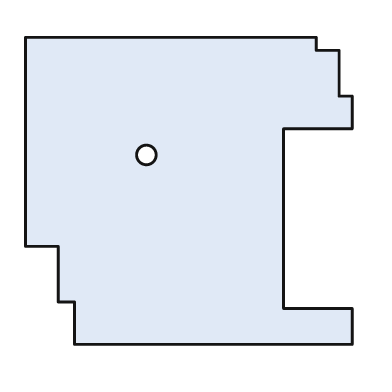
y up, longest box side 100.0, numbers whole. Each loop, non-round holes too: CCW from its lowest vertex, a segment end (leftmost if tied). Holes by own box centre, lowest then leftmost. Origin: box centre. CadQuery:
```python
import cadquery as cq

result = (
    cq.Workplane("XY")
    .moveTo(-35.0, -47.0)
    .lineTo(50.0, -47.0)
    .lineTo(50.0, -36.0)
    .lineTo(29.0, -36.0)
    .lineTo(29.0, 19.0)
    .lineTo(50.0, 19.0)
    .lineTo(50.0, 29.0)
    .lineTo(46.0, 29.0)
    .lineTo(46.0, 43.0)
    .lineTo(39.0, 43.0)
    .lineTo(39.0, 47.0)
    .lineTo(-50.0, 47.0)
    .lineTo(-50.0, -17.0)
    .lineTo(-40.0, -17.0)
    .lineTo(-40.0, -34.0)
    .lineTo(-35.0, -34.0)
    .close()
    .moveTo(-13.0, 11.0)
    .circle(3.0)
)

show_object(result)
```